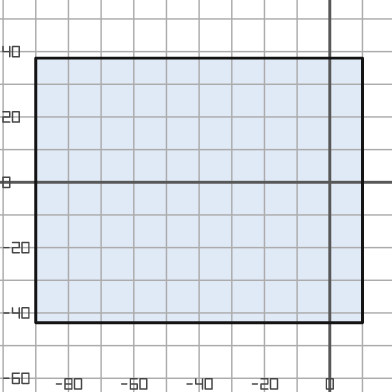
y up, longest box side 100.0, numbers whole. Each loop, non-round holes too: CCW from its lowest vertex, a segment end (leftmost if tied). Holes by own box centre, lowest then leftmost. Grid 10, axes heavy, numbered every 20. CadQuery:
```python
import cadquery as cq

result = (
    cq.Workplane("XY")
    .moveTo(-90.0, -43.0)
    .lineTo(10.0, -43.0)
    .lineTo(10.0, 38.0)
    .lineTo(-90.0, 38.0)
    .close()
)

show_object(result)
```